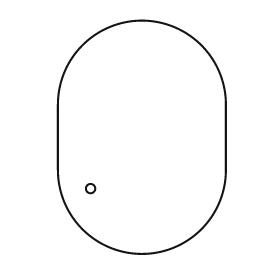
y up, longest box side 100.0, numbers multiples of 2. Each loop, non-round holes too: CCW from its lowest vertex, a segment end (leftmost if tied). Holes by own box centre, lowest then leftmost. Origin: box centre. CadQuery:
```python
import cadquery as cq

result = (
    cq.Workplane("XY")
    .moveTo(-36.0, -14.0)
    .threePointArc((0.0, -50.0), (36.0, -14.0))
    .lineTo(36.0, 14.0)
    .threePointArc((0.0, 50.0), (-36.0, 14.0))
    .close()
    .moveTo(-22.0, -22.0)
    .circle(2.0)
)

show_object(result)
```